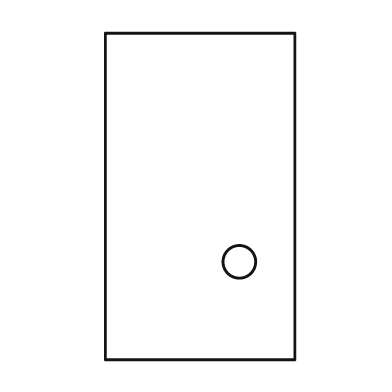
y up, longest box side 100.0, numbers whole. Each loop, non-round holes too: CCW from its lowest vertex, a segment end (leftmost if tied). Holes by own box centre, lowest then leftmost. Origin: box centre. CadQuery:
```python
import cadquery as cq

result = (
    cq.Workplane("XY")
    .moveTo(-29.0, -50.0)
    .lineTo(29.0, -50.0)
    .lineTo(29.0, 50.0)
    .lineTo(-29.0, 50.0)
    .close()
    .moveTo(12.0, -20.0)
    .circle(5.0)
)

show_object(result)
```